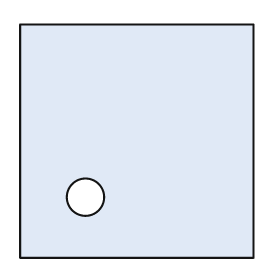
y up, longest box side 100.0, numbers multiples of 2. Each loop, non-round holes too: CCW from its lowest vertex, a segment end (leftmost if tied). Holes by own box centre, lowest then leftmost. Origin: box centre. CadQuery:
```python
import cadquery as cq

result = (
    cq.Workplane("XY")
    .moveTo(-50.0, -50.0)
    .lineTo(50.0, -50.0)
    .lineTo(50.0, 50.0)
    .lineTo(-50.0, 50.0)
    .close()
    .moveTo(-22.0, -24.0)
    .circle(8.0)
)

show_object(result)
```